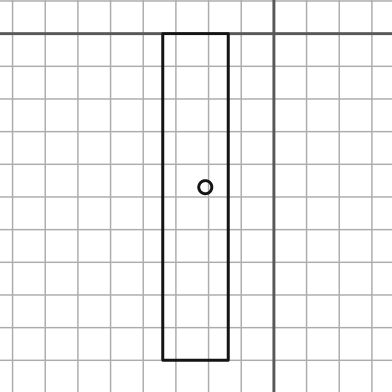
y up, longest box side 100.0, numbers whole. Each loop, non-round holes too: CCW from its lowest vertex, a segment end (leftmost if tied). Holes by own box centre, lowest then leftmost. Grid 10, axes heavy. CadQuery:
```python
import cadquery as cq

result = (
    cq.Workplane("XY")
    .moveTo(-34.0, -100.0)
    .lineTo(-14.0, -100.0)
    .lineTo(-14.0, 0.0)
    .lineTo(-34.0, 0.0)
    .close()
    .moveTo(-21.0, -47.0)
    .circle(2.0)
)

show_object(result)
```